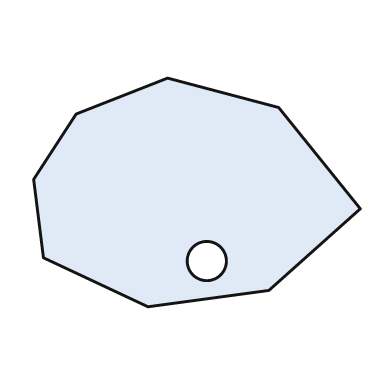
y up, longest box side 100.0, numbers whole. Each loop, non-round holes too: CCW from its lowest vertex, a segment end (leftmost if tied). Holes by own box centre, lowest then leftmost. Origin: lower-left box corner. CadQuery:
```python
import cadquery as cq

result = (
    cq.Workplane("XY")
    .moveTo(35.0, 0.0)
    .lineTo(72.0, 5.0)
    .lineTo(100.0, 30.0)
    .lineTo(75.0, 61.0)
    .lineTo(41.0, 70.0)
    .lineTo(13.0, 59.0)
    .lineTo(0.0, 39.0)
    .lineTo(3.0, 15.0)
    .close()
    .moveTo(53.0, 14.0)
    .circle(6.0)
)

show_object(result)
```